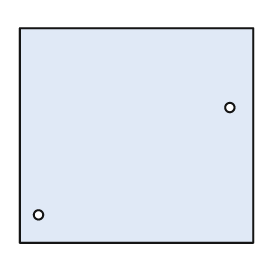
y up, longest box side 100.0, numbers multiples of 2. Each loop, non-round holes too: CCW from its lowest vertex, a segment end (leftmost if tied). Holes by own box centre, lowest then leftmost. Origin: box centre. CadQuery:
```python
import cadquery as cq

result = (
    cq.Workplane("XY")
    .moveTo(-50.0, -46.0)
    .lineTo(50.0, -46.0)
    .lineTo(50.0, 46.0)
    .lineTo(-50.0, 46.0)
    .close()
    .moveTo(-42.0, -34.0)
    .circle(2.0)
    .moveTo(40.0, 12.0)
    .circle(2.0)
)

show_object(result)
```